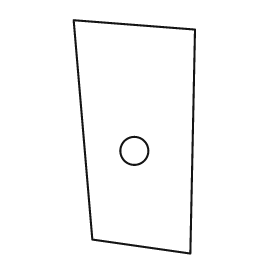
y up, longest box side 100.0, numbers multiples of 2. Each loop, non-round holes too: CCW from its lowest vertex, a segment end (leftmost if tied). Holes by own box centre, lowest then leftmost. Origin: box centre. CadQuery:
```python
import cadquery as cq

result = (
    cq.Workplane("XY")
    .moveTo(24.0, -50.0)
    .lineTo(26.0, 46.0)
    .lineTo(-26.0, 50.0)
    .lineTo(-18.0, -44.0)
    .close()
    .moveTo(0.0, -6.0)
    .circle(6.0)
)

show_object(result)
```